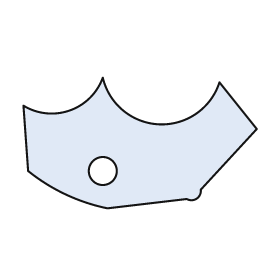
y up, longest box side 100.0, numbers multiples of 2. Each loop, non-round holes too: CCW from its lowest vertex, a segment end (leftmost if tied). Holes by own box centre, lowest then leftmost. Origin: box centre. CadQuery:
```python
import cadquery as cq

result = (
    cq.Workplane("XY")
    .moveTo(-14.0, -28.0)
    .lineTo(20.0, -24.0)
    .threePointArc((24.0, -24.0), (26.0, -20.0))
    .lineTo(50.0, 6.0)
    .lineTo(34.0, 26.0)
    .threePointArc((8.0, 8.0), (-16.0, 28.0))
    .threePointArc((-30.0, 14.0), (-50.0, 16.0))
    .lineTo(-48.0, -12.0)
    .threePointArc((-32.0, -22.0), (-14.0, -28.0))
    .close()
    .moveTo(-16.0, -12.0)
    .circle(6.0)
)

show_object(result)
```